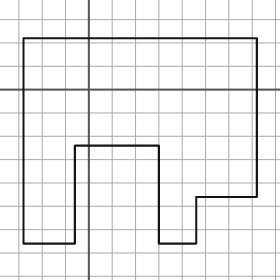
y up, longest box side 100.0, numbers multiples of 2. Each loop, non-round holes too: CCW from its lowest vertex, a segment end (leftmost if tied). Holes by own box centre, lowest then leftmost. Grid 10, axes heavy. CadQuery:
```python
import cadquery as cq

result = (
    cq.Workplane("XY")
    .moveTo(-28.0, -66.0)
    .lineTo(-6.0, -66.0)
    .lineTo(-6.0, -24.0)
    .lineTo(30.0, -24.0)
    .lineTo(30.0, -66.0)
    .lineTo(46.0, -66.0)
    .lineTo(46.0, -46.0)
    .lineTo(72.0, -46.0)
    .lineTo(72.0, 22.0)
    .lineTo(-28.0, 22.0)
    .close()
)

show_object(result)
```